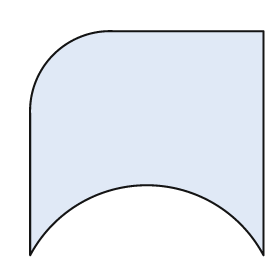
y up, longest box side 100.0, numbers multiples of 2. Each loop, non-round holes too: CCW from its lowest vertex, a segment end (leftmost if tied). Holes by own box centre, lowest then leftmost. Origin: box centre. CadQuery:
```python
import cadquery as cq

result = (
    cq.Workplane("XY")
    .moveTo(-50.0, -48.0)
    .threePointArc((0.0, -18.0), (50.0, -48.0))
    .lineTo(50.0, 48.0)
    .lineTo(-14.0, 48.0)
    .threePointArc((-40.0, 38.0), (-50.0, 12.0))
    .close()
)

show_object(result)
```